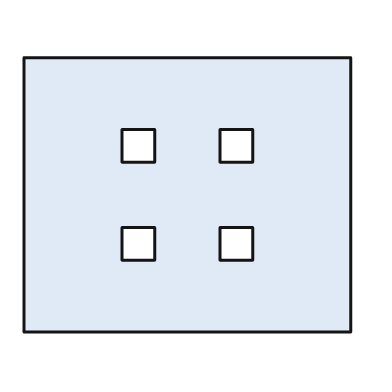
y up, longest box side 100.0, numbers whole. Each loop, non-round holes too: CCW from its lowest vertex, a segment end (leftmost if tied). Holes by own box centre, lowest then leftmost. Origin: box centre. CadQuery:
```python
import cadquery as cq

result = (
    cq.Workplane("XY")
    .moveTo(-50.0, -42.0)
    .lineTo(50.0, -42.0)
    .lineTo(50.0, 42.0)
    .lineTo(-50.0, 42.0)
    .close()
    .moveTo(-20.0, -20.0)
    .lineTo(-10.0, -20.0)
    .lineTo(-10.0, -10.0)
    .lineTo(-20.0, -10.0)
    .close()
    .moveTo(10.0, -20.0)
    .lineTo(20.0, -20.0)
    .lineTo(20.0, -10.0)
    .lineTo(10.0, -10.0)
    .close()
    .moveTo(-20.0, 10.0)
    .lineTo(-10.0, 10.0)
    .lineTo(-10.0, 20.0)
    .lineTo(-20.0, 20.0)
    .close()
    .moveTo(10.0, 10.0)
    .lineTo(20.0, 10.0)
    .lineTo(20.0, 20.0)
    .lineTo(10.0, 20.0)
    .close()
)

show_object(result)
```